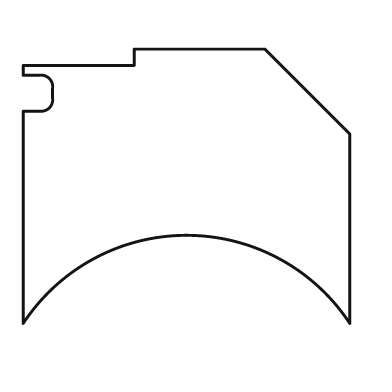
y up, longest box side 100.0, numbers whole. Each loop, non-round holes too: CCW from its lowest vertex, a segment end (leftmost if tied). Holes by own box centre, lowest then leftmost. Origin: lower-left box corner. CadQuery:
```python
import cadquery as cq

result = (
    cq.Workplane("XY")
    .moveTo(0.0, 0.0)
    .threePointArc((50.0, 27.0), (100.0, 0.0))
    .lineTo(100.0, 58.0)
    .lineTo(74.0, 84.0)
    .lineTo(34.0, 84.0)
    .lineTo(34.0, 79.0)
    .lineTo(0.0, 79.0)
    .lineTo(0.0, 76.0)
    .lineTo(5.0, 76.0)
    .threePointArc((8.0, 75.0), (9.0, 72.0))
    .lineTo(9.0, 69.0)
    .threePointArc((8.0, 66.0), (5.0, 65.0))
    .lineTo(0.0, 65.0)
    .close()
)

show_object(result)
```